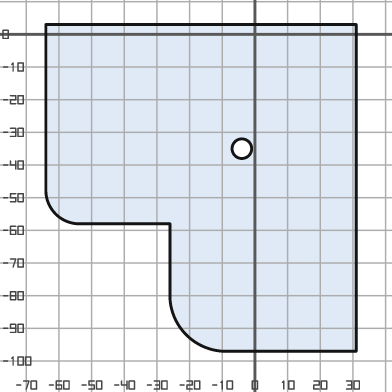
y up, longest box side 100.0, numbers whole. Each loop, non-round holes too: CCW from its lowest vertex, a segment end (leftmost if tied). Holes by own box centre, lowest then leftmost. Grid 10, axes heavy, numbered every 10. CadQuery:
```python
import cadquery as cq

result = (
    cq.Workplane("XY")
    .moveTo(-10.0, -97.0)
    .lineTo(31.0, -97.0)
    .lineTo(31.0, 3.0)
    .lineTo(-64.0, 3.0)
    .lineTo(-64.0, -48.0)
    .threePointArc((-61.0, -55.0), (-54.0, -58.0))
    .lineTo(-26.0, -58.0)
    .lineTo(-26.0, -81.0)
    .threePointArc((-21.0, -92.0), (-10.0, -97.0))
    .close()
    .moveTo(-4.0, -35.0)
    .circle(3.0)
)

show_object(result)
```